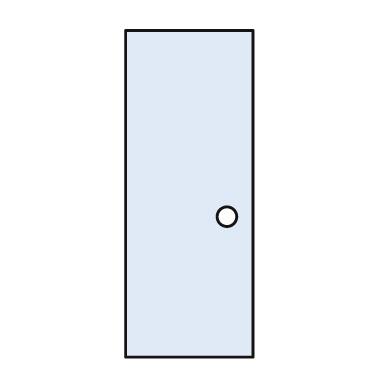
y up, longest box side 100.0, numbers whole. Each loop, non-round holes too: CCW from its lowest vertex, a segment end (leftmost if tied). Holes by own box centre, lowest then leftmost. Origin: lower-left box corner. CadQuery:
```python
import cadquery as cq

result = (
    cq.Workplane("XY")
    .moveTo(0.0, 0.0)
    .lineTo(39.0, 0.0)
    .lineTo(39.0, 100.0)
    .lineTo(0.0, 100.0)
    .close()
    .moveTo(31.0, 43.0)
    .circle(3.0)
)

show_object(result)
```